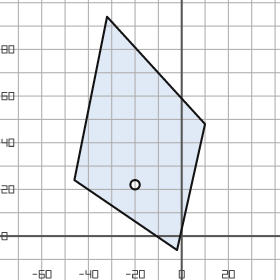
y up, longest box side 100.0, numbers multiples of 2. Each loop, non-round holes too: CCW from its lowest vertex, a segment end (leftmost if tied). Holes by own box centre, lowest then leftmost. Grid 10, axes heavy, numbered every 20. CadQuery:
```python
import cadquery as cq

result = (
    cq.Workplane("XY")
    .moveTo(-2.0, -6.0)
    .lineTo(10.0, 48.0)
    .lineTo(-32.0, 94.0)
    .lineTo(-46.0, 24.0)
    .close()
    .moveTo(-20.0, 22.0)
    .circle(2.0)
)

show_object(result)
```